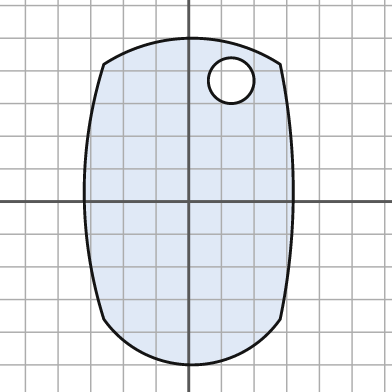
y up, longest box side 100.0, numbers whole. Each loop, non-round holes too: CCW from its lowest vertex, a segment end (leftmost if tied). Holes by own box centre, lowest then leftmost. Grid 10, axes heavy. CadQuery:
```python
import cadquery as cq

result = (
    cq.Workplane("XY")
    .moveTo(-26.0, -36.0)
    .threePointArc((1.0, -50.0), (28.0, -36.0))
    .threePointArc((32.0, 3.0), (28.0, 42.0))
    .threePointArc((1.0, 50.0), (-26.0, 42.0))
    .threePointArc((-32.0, 3.0), (-26.0, -36.0))
    .close()
    .moveTo(13.0, 37.0)
    .circle(7.0)
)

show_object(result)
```